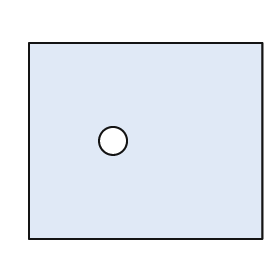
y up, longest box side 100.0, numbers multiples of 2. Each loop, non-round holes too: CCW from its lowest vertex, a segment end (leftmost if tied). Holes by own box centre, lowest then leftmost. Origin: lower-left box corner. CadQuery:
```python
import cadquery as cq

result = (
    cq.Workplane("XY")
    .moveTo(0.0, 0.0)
    .lineTo(100.0, 0.0)
    .lineTo(100.0, 84.0)
    .lineTo(0.0, 84.0)
    .close()
    .moveTo(36.0, 42.0)
    .circle(6.0)
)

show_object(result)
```